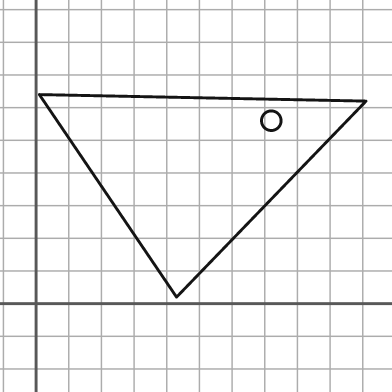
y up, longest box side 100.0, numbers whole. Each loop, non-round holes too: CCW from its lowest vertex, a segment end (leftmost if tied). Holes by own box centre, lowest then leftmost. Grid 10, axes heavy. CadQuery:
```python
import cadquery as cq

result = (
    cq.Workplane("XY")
    .moveTo(43.0, 2.0)
    .lineTo(101.0, 62.0)
    .lineTo(1.0, 64.0)
    .close()
    .moveTo(72.0, 56.0)
    .circle(3.0)
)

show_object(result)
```